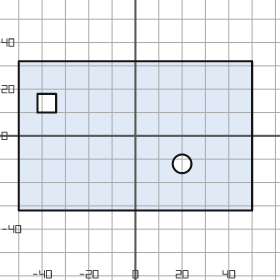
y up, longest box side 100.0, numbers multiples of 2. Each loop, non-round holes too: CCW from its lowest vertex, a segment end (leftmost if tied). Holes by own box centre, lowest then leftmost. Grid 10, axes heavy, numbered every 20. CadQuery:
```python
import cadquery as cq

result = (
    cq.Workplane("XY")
    .moveTo(-50.0, -32.0)
    .lineTo(50.0, -32.0)
    .lineTo(50.0, 32.0)
    .lineTo(-50.0, 32.0)
    .close()
    .moveTo(20.0, -12.0)
    .circle(4.0)
    .moveTo(-42.0, 10.0)
    .lineTo(-34.0, 10.0)
    .lineTo(-34.0, 18.0)
    .lineTo(-42.0, 18.0)
    .close()
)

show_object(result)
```